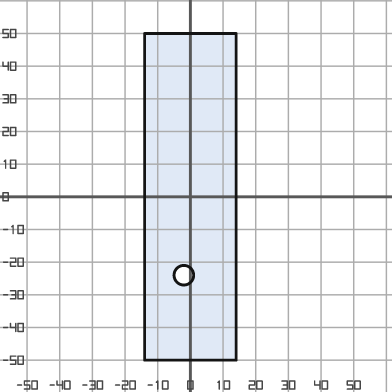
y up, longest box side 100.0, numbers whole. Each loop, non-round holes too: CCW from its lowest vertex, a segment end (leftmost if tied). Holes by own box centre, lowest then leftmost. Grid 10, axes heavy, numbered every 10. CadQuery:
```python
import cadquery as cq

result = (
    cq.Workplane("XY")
    .moveTo(-14.0, -50.0)
    .lineTo(14.0, -50.0)
    .lineTo(14.0, 50.0)
    .lineTo(-14.0, 50.0)
    .close()
    .moveTo(-2.0, -24.0)
    .circle(3.0)
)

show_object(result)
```